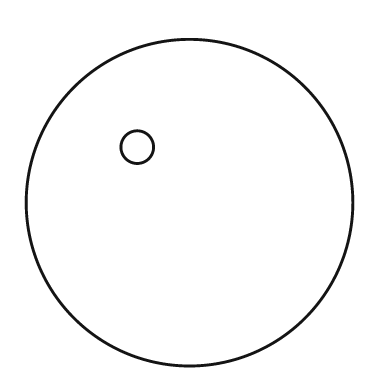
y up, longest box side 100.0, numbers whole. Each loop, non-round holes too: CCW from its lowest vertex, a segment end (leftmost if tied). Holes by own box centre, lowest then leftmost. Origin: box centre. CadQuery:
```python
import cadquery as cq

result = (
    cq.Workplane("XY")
    .moveTo(0.0, 0.0)
    .circle(50.0)
    .moveTo(-16.0, 17.0)
    .circle(5.0)
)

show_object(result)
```